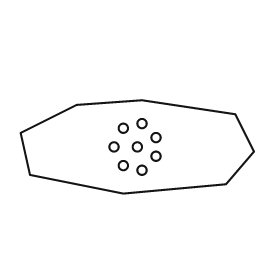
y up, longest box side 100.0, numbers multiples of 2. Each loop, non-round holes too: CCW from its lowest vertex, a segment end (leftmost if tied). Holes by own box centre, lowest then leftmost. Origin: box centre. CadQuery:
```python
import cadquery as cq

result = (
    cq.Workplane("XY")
    .moveTo(-6.0, -20.0)
    .lineTo(38.0, -16.0)
    .lineTo(50.0, -2.0)
    .lineTo(42.0, 14.0)
    .lineTo(2.0, 20.0)
    .lineTo(-26.0, 18.0)
    .lineTo(-50.0, 6.0)
    .lineTo(-46.0, -12.0)
    .close()
    .moveTo(2.0, -10.0)
    .circle(2.0)
    .moveTo(-6.0, -8.0)
    .circle(2.0)
    .moveTo(8.0, -4.0)
    .circle(2.0)
    .moveTo(-10.0, 0.0)
    .circle(2.0)
    .moveTo(0.0, 0.0)
    .circle(2.0)
    .moveTo(8.0, 4.0)
    .circle(2.0)
    .moveTo(-6.0, 8.0)
    .circle(2.0)
    .moveTo(2.0, 10.0)
    .circle(2.0)
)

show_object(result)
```